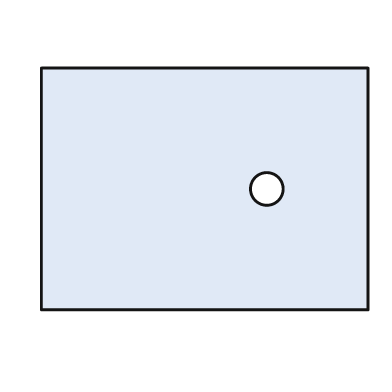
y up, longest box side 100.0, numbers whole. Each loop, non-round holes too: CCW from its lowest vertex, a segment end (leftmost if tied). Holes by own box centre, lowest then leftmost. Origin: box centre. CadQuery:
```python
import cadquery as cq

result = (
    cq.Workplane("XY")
    .moveTo(-50.0, -37.0)
    .lineTo(50.0, -37.0)
    .lineTo(50.0, 37.0)
    .lineTo(-50.0, 37.0)
    .close()
    .moveTo(19.0, 0.0)
    .circle(5.0)
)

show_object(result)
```